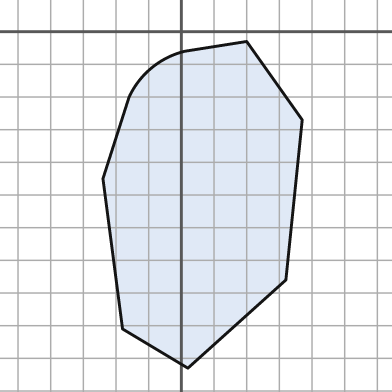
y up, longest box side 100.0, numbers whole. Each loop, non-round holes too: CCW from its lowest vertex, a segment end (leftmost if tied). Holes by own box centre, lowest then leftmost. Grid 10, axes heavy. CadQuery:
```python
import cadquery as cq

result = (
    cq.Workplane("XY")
    .moveTo(2.0, -103.0)
    .lineTo(32.0, -76.0)
    .lineTo(37.0, -27.0)
    .lineTo(20.0, -3.0)
    .lineTo(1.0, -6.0)
    .threePointArc((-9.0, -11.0), (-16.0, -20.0))
    .lineTo(-24.0, -45.0)
    .lineTo(-18.0, -91.0)
    .close()
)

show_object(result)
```